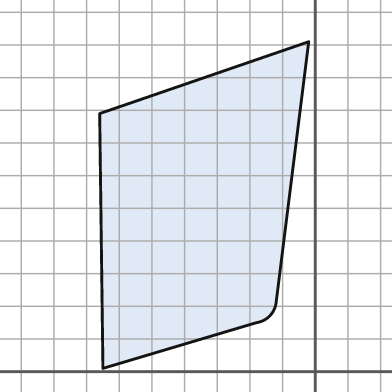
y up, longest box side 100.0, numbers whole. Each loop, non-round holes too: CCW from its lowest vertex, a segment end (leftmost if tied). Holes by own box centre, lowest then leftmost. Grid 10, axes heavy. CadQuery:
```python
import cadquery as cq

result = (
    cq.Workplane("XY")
    .moveTo(-65.0, 1.0)
    .lineTo(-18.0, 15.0)
    .threePointArc((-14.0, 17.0), (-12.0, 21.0))
    .lineTo(-2.0, 101.0)
    .lineTo(-66.0, 79.0)
    .close()
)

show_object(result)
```